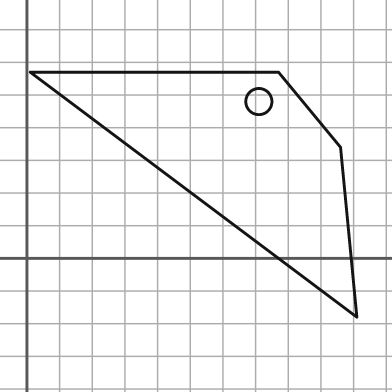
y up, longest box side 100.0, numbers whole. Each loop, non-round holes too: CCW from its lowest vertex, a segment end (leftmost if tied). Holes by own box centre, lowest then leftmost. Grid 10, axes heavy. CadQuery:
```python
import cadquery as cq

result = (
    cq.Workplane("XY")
    .moveTo(101.0, -18.0)
    .lineTo(96.0, 34.0)
    .lineTo(77.0, 57.0)
    .lineTo(1.0, 57.0)
    .close()
    .moveTo(71.0, 48.0)
    .circle(4.0)
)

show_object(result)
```